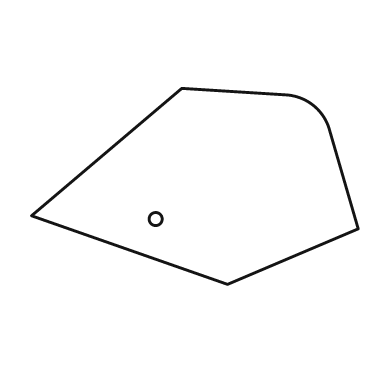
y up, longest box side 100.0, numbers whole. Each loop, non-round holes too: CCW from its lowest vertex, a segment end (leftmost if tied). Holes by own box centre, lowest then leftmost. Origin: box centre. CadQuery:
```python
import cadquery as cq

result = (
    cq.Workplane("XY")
    .moveTo(10.0, -30.0)
    .lineTo(50.0, -13.0)
    .lineTo(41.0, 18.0)
    .threePointArc((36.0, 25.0), (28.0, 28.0))
    .lineTo(-4.0, 30.0)
    .lineTo(-50.0, -9.0)
    .close()
    .moveTo(-12.0, -10.0)
    .circle(2.0)
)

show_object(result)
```